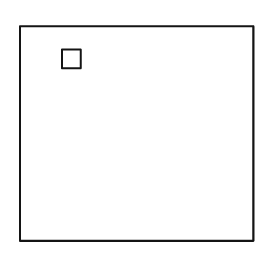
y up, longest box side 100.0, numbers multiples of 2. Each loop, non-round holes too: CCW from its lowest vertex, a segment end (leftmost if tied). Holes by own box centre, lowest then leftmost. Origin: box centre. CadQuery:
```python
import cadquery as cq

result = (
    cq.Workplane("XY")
    .moveTo(-50.0, -46.0)
    .lineTo(50.0, -46.0)
    .lineTo(50.0, 46.0)
    .lineTo(-50.0, 46.0)
    .close()
    .moveTo(-32.0, 28.0)
    .lineTo(-24.0, 28.0)
    .lineTo(-24.0, 36.0)
    .lineTo(-32.0, 36.0)
    .close()
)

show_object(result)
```